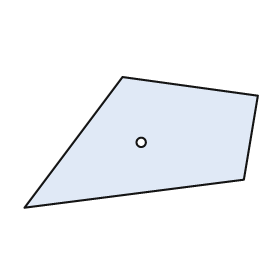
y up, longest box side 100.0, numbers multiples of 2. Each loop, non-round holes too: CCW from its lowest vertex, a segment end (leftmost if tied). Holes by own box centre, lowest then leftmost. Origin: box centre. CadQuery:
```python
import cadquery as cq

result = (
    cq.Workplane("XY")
    .moveTo(-50.0, -28.0)
    .lineTo(44.0, -16.0)
    .lineTo(50.0, 20.0)
    .lineTo(-8.0, 28.0)
    .close()
    .moveTo(0.0, 0.0)
    .circle(2.0)
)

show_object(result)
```